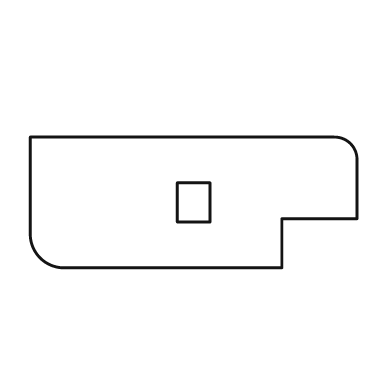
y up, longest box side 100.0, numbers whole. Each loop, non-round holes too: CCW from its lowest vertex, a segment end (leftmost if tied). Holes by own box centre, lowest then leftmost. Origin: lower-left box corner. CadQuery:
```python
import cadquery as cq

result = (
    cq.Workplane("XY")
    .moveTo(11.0, 0.0)
    .lineTo(77.0, 0.0)
    .lineTo(77.0, 15.0)
    .lineTo(100.0, 15.0)
    .lineTo(100.0, 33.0)
    .threePointArc((98.0, 38.0), (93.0, 40.0))
    .lineTo(0.0, 40.0)
    .lineTo(0.0, 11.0)
    .threePointArc((3.0, 3.0), (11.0, 0.0))
    .close()
    .moveTo(45.0, 14.0)
    .lineTo(55.0, 14.0)
    .lineTo(55.0, 26.0)
    .lineTo(45.0, 26.0)
    .close()
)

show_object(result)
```